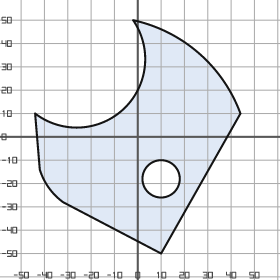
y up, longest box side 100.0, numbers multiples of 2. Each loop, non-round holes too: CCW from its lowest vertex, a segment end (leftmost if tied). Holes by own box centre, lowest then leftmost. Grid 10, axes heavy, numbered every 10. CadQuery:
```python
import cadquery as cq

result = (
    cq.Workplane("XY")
    .moveTo(10.0, -50.0)
    .lineTo(44.0, 10.0)
    .threePointArc((26.0, 36.0), (-2.0, 50.0))
    .threePointArc((-6.0, 12.0), (-44.0, 10.0))
    .lineTo(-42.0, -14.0)
    .threePointArc((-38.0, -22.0), (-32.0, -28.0))
    .close()
    .moveTo(10.0, -18.0)
    .circle(8.0)
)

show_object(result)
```